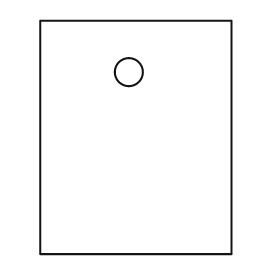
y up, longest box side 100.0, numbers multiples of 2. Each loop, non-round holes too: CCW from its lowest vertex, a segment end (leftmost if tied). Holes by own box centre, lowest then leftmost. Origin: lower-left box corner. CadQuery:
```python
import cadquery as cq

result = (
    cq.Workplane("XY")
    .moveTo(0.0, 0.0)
    .lineTo(82.0, 0.0)
    .lineTo(82.0, 100.0)
    .lineTo(0.0, 100.0)
    .close()
    .moveTo(38.0, 78.0)
    .circle(6.0)
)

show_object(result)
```